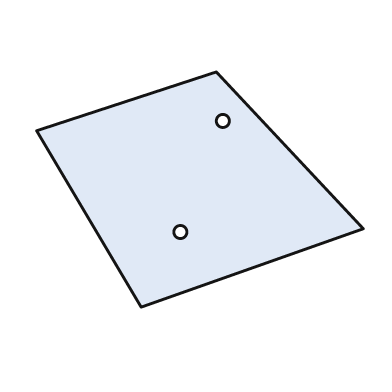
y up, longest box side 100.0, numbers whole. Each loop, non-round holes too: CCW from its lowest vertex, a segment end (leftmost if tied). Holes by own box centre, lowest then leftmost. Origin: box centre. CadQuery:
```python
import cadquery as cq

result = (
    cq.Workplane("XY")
    .moveTo(-18.0, -36.0)
    .lineTo(50.0, -12.0)
    .lineTo(5.0, 36.0)
    .lineTo(-50.0, 18.0)
    .close()
    .moveTo(-6.0, -13.0)
    .circle(2.0)
    .moveTo(7.0, 21.0)
    .circle(2.0)
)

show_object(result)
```